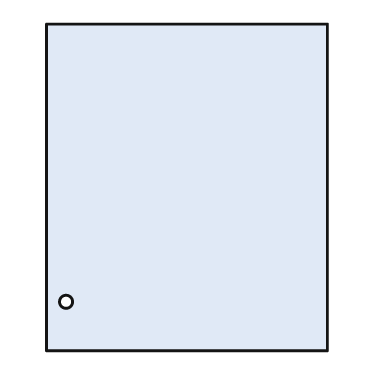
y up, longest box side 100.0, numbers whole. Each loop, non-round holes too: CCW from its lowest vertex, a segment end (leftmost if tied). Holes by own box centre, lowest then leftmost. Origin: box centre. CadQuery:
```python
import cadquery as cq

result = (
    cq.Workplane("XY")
    .moveTo(-43.0, -50.0)
    .lineTo(43.0, -50.0)
    .lineTo(43.0, 50.0)
    .lineTo(-43.0, 50.0)
    .close()
    .moveTo(-37.0, -35.0)
    .circle(2.0)
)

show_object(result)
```